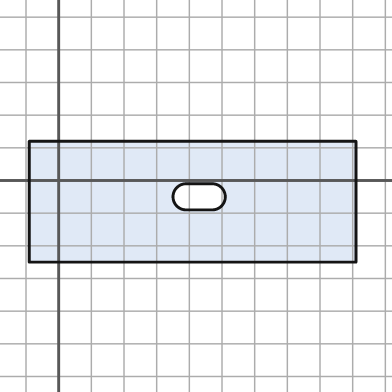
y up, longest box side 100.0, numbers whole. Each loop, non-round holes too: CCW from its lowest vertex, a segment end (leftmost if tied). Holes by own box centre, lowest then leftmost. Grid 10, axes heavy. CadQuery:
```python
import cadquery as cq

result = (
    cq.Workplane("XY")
    .moveTo(-9.0, -25.0)
    .lineTo(91.0, -25.0)
    .lineTo(91.0, 12.0)
    .lineTo(-9.0, 12.0)
    .close()
    .moveTo(39.0, -9.0)
    .lineTo(47.0, -9.0)
    .threePointArc((51.0, -5.0), (47.0, -1.0))
    .lineTo(39.0, -1.0)
    .threePointArc((35.0, -5.0), (39.0, -9.0))
    .close()
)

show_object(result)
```